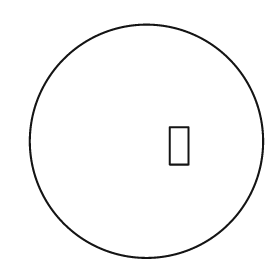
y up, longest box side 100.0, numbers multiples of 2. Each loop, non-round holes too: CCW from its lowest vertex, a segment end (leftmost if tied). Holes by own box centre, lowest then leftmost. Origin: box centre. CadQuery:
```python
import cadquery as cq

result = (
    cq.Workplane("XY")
    .moveTo(0.0, 0.0)
    .circle(50.0)
    .moveTo(10.0, -10.0)
    .lineTo(18.0, -10.0)
    .lineTo(18.0, 6.0)
    .lineTo(10.0, 6.0)
    .close()
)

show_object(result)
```